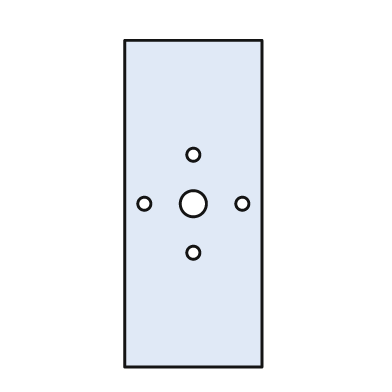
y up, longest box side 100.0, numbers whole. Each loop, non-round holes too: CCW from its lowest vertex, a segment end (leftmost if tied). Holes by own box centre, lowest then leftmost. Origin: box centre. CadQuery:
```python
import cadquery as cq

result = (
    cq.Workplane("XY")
    .moveTo(-21.0, -50.0)
    .lineTo(21.0, -50.0)
    .lineTo(21.0, 50.0)
    .lineTo(-21.0, 50.0)
    .close()
    .moveTo(0.0, -15.0)
    .circle(2.0)
    .moveTo(-15.0, 0.0)
    .circle(2.0)
    .moveTo(0.0, 0.0)
    .circle(4.0)
    .moveTo(15.0, 0.0)
    .circle(2.0)
    .moveTo(0.0, 15.0)
    .circle(2.0)
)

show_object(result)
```